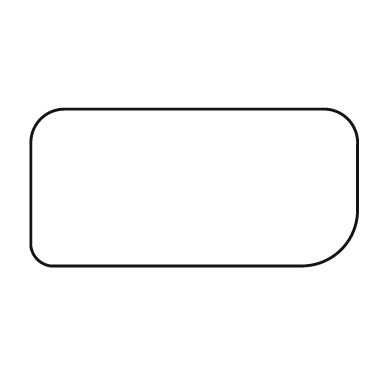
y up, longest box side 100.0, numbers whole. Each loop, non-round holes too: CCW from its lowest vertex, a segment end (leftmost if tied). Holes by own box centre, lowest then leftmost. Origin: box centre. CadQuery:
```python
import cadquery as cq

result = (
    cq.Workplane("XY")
    .moveTo(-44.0, -24.0)
    .lineTo(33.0, -24.0)
    .threePointArc((45.0, -19.0), (50.0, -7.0))
    .lineTo(50.0, 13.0)
    .threePointArc((47.0, 21.0), (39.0, 24.0))
    .lineTo(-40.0, 24.0)
    .threePointArc((-47.0, 21.0), (-50.0, 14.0))
    .lineTo(-50.0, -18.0)
    .threePointArc((-48.0, -22.0), (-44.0, -24.0))
    .close()
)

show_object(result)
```